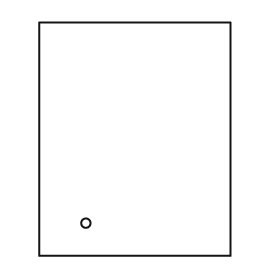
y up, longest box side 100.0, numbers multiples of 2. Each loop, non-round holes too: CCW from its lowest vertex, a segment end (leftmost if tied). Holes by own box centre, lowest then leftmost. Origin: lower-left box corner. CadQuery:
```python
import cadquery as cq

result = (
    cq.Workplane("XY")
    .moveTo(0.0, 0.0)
    .lineTo(82.0, 0.0)
    .lineTo(82.0, 100.0)
    .lineTo(0.0, 100.0)
    .close()
    .moveTo(20.0, 14.0)
    .circle(2.0)
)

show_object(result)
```